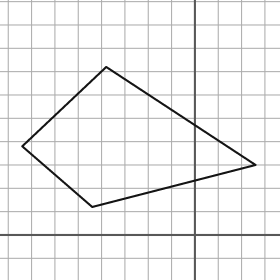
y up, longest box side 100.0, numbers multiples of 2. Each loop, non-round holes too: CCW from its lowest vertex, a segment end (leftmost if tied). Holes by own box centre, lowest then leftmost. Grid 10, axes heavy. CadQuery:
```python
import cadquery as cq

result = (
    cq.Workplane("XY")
    .moveTo(-44.0, 12.0)
    .lineTo(26.0, 30.0)
    .lineTo(-38.0, 72.0)
    .lineTo(-74.0, 38.0)
    .close()
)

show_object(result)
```